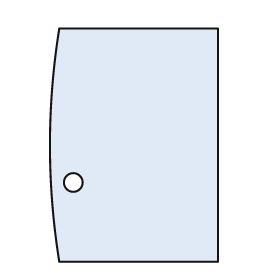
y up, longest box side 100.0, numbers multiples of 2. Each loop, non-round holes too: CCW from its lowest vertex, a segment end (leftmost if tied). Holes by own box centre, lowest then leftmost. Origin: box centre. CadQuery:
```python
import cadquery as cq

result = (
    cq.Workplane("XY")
    .moveTo(-32.0, -50.0)
    .lineTo(36.0, -50.0)
    .lineTo(36.0, 50.0)
    .lineTo(-32.0, 50.0)
    .threePointArc((-36.0, 0.0), (-32.0, -50.0))
    .close()
    .moveTo(-26.0, -16.0)
    .circle(4.0)
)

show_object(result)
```